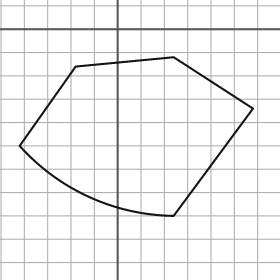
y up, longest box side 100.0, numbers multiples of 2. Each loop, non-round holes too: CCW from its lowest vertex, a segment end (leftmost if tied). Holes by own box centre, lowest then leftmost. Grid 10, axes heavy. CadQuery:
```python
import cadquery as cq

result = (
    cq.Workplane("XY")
    .moveTo(24.0, -80.0)
    .lineTo(58.0, -34.0)
    .lineTo(24.0, -12.0)
    .lineTo(-18.0, -16.0)
    .lineTo(-42.0, -50.0)
    .threePointArc((-12.0, -72.0), (24.0, -80.0))
    .close()
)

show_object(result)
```